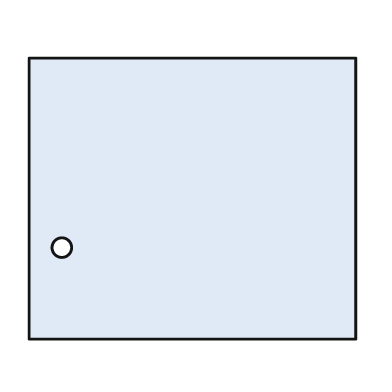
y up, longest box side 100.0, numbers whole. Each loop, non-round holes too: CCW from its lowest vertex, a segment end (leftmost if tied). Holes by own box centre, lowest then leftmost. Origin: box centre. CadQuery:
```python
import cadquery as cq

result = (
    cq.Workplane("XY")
    .moveTo(-50.0, -43.0)
    .lineTo(50.0, -43.0)
    .lineTo(50.0, 43.0)
    .lineTo(-50.0, 43.0)
    .close()
    .moveTo(-40.0, -15.0)
    .circle(3.0)
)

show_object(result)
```